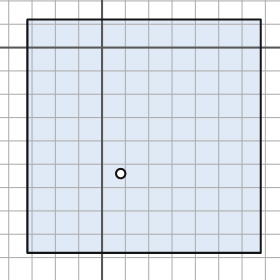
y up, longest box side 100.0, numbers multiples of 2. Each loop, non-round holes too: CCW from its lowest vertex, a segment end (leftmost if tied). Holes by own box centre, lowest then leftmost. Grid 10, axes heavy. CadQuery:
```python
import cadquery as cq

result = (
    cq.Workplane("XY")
    .moveTo(-32.0, -88.0)
    .lineTo(68.0, -88.0)
    .lineTo(68.0, 12.0)
    .lineTo(-32.0, 12.0)
    .close()
    .moveTo(8.0, -54.0)
    .circle(2.0)
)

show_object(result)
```